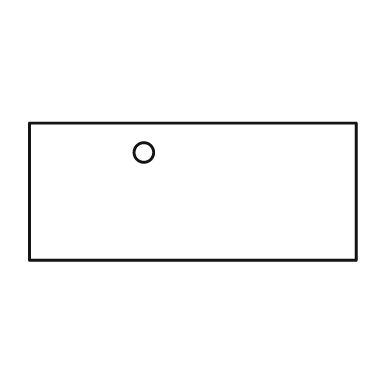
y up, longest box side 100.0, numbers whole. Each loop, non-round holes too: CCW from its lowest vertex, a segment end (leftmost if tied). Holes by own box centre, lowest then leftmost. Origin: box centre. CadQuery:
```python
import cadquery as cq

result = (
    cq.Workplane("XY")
    .moveTo(-50.0, -21.0)
    .lineTo(50.0, -21.0)
    .lineTo(50.0, 21.0)
    .lineTo(-50.0, 21.0)
    .close()
    .moveTo(-15.0, 12.0)
    .circle(3.0)
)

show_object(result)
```